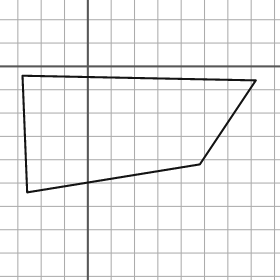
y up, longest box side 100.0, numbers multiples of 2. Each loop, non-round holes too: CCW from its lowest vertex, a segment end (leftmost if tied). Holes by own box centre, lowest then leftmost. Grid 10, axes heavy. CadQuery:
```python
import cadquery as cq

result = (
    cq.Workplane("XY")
    .moveTo(-26.0, -54.0)
    .lineTo(48.0, -42.0)
    .lineTo(72.0, -6.0)
    .lineTo(-28.0, -4.0)
    .close()
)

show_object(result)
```